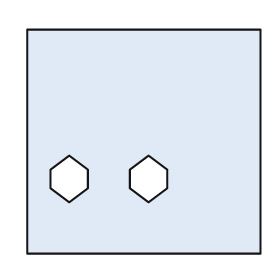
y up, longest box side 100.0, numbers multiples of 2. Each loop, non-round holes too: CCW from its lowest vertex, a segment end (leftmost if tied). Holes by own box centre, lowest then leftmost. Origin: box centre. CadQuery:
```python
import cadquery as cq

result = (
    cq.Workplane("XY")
    .moveTo(-50.0, -48.0)
    .lineTo(50.0, -48.0)
    .lineTo(50.0, 48.0)
    .lineTo(-50.0, 48.0)
    .close()
    .moveTo(-32.0, -26.0)
    .lineTo(-24.0, -20.0)
    .lineTo(-24.0, -12.0)
    .lineTo(-32.0, -6.0)
    .lineTo(-40.0, -12.0)
    .lineTo(-40.0, -20.0)
    .close()
    .moveTo(2.0, -26.0)
    .lineTo(10.0, -20.0)
    .lineTo(10.0, -12.0)
    .lineTo(2.0, -6.0)
    .lineTo(-6.0, -12.0)
    .lineTo(-6.0, -20.0)
    .close()
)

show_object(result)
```